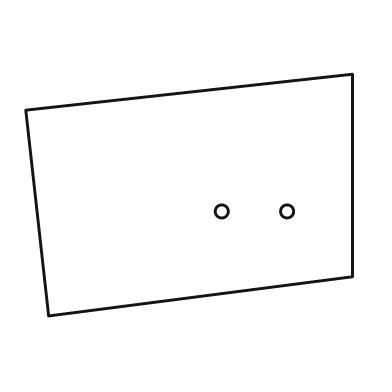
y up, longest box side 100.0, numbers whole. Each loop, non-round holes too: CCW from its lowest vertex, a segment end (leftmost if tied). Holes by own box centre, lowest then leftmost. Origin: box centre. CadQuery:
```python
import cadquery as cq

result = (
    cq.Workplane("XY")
    .moveTo(-43.0, -37.0)
    .lineTo(50.0, -25.0)
    .lineTo(50.0, 37.0)
    .lineTo(-50.0, 26.0)
    .close()
    .moveTo(10.0, -5.0)
    .circle(2.0)
    .moveTo(30.0, -5.0)
    .circle(2.0)
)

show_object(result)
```